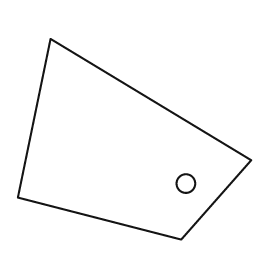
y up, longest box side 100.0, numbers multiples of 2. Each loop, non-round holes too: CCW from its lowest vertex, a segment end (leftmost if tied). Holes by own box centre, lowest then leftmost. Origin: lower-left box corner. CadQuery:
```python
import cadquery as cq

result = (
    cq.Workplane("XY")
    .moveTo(70.0, 0.0)
    .lineTo(100.0, 34.0)
    .lineTo(14.0, 86.0)
    .lineTo(0.0, 18.0)
    .close()
    .moveTo(72.0, 24.0)
    .circle(4.0)
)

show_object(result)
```